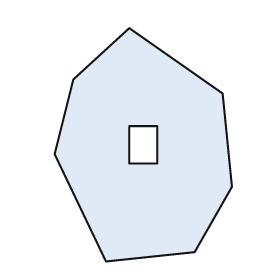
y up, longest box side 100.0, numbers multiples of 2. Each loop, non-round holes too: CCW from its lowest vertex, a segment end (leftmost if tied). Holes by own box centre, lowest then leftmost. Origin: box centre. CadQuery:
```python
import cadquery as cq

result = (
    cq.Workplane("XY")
    .moveTo(-16.0, -50.0)
    .lineTo(22.0, -46.0)
    .lineTo(38.0, -18.0)
    .lineTo(34.0, 22.0)
    .lineTo(-6.0, 50.0)
    .lineTo(-30.0, 28.0)
    .lineTo(-38.0, -4.0)
    .close()
    .moveTo(-6.0, -8.0)
    .lineTo(6.0, -8.0)
    .lineTo(6.0, 8.0)
    .lineTo(-6.0, 8.0)
    .close()
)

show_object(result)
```